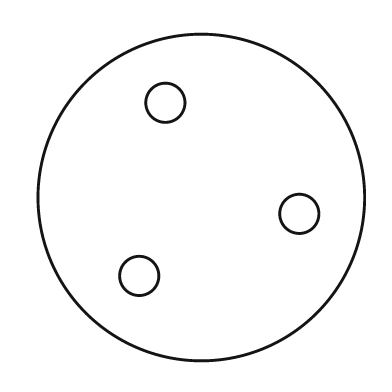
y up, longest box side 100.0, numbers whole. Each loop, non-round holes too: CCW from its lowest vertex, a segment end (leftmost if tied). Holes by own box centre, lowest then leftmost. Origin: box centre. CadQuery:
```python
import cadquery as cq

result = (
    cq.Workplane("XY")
    .moveTo(0.0, 0.0)
    .circle(50.0)
    .moveTo(-19.0, -24.0)
    .circle(6.0)
    .moveTo(30.0, -5.0)
    .circle(6.0)
    .moveTo(-11.0, 29.0)
    .circle(6.0)
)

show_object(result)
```